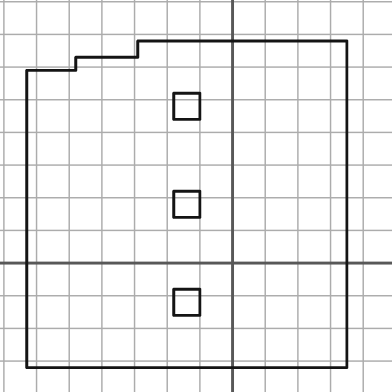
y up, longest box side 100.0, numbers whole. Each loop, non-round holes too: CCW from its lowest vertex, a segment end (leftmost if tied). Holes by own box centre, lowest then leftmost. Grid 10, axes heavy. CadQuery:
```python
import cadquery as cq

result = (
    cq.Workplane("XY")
    .moveTo(-63.0, -32.0)
    .lineTo(35.0, -32.0)
    .lineTo(35.0, 68.0)
    .lineTo(-29.0, 68.0)
    .lineTo(-29.0, 63.0)
    .lineTo(-48.0, 63.0)
    .lineTo(-48.0, 59.0)
    .lineTo(-63.0, 59.0)
    .close()
    .moveTo(-18.0, -16.0)
    .lineTo(-10.0, -16.0)
    .lineTo(-10.0, -8.0)
    .lineTo(-18.0, -8.0)
    .close()
    .moveTo(-18.0, 14.0)
    .lineTo(-10.0, 14.0)
    .lineTo(-10.0, 22.0)
    .lineTo(-18.0, 22.0)
    .close()
    .moveTo(-18.0, 44.0)
    .lineTo(-10.0, 44.0)
    .lineTo(-10.0, 52.0)
    .lineTo(-18.0, 52.0)
    .close()
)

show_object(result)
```